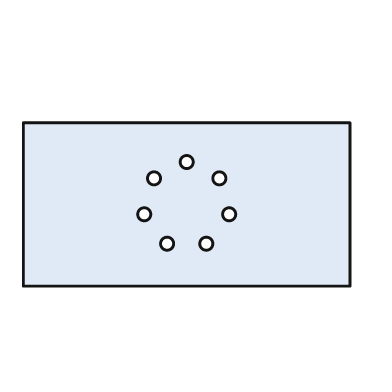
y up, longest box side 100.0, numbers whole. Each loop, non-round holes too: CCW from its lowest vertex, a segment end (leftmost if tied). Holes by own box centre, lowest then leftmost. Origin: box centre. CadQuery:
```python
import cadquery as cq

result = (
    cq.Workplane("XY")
    .moveTo(-50.0, -25.0)
    .lineTo(50.0, -25.0)
    .lineTo(50.0, 25.0)
    .lineTo(-50.0, 25.0)
    .close()
    .moveTo(-6.0, -12.0)
    .circle(2.0)
    .moveTo(6.0, -12.0)
    .circle(2.0)
    .moveTo(-13.0, -3.0)
    .circle(2.0)
    .moveTo(13.0, -3.0)
    .circle(2.0)
    .moveTo(-10.0, 8.0)
    .circle(2.0)
    .moveTo(10.0, 8.0)
    .circle(2.0)
    .moveTo(0.0, 13.0)
    .circle(2.0)
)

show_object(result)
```